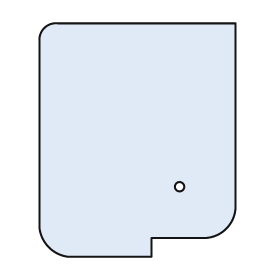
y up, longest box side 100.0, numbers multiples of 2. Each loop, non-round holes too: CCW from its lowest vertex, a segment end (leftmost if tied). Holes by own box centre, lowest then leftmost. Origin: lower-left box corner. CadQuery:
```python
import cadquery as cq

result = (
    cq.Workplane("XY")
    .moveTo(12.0, 0.0)
    .lineTo(48.0, 0.0)
    .lineTo(48.0, 8.0)
    .lineTo(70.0, 8.0)
    .threePointArc((80.0, 12.0), (84.0, 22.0))
    .lineTo(84.0, 100.0)
    .lineTo(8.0, 100.0)
    .threePointArc((2.0, 98.0), (0.0, 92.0))
    .lineTo(0.0, 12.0)
    .threePointArc((4.0, 4.0), (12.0, 0.0))
    .close()
    .moveTo(60.0, 30.0)
    .circle(2.0)
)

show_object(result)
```